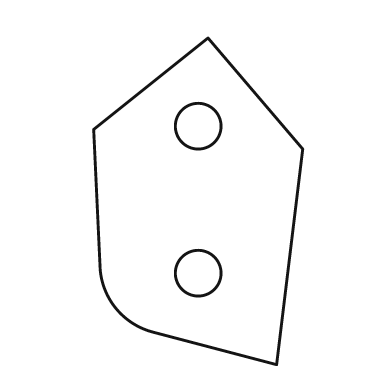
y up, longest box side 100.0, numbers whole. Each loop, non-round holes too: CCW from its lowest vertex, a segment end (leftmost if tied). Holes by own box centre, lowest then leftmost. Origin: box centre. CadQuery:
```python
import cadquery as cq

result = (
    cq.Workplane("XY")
    .moveTo(24.0, -50.0)
    .lineTo(32.0, 16.0)
    .lineTo(3.0, 50.0)
    .lineTo(-32.0, 22.0)
    .lineTo(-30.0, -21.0)
    .threePointArc((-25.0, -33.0), (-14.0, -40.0))
    .close()
    .moveTo(0.0, -22.0)
    .circle(7.0)
    .moveTo(0.0, 23.0)
    .circle(7.0)
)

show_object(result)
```